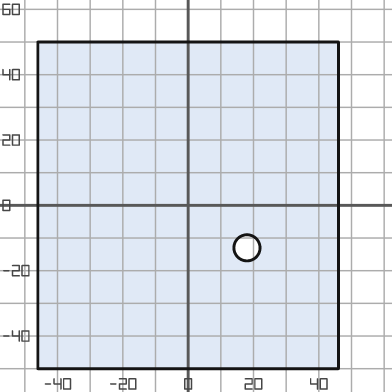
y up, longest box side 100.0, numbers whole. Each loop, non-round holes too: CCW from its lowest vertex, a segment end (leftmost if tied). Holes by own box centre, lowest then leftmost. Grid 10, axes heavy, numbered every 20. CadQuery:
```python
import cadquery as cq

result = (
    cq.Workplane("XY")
    .moveTo(-46.0, -50.0)
    .lineTo(46.0, -50.0)
    .lineTo(46.0, 50.0)
    .lineTo(-46.0, 50.0)
    .close()
    .moveTo(18.0, -13.0)
    .circle(4.0)
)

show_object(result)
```